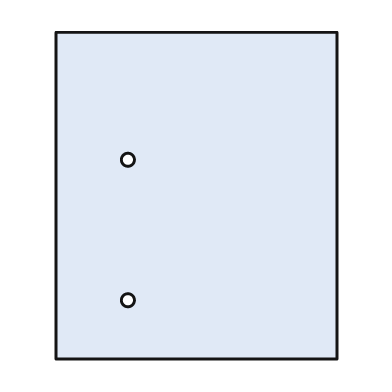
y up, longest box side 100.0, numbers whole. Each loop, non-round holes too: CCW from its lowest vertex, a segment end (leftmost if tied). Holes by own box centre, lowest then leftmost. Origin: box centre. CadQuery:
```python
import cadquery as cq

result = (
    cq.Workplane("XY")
    .moveTo(-43.0, -50.0)
    .lineTo(43.0, -50.0)
    .lineTo(43.0, 50.0)
    .lineTo(-43.0, 50.0)
    .close()
    .moveTo(-21.0, -32.0)
    .circle(2.0)
    .moveTo(-21.0, 11.0)
    .circle(2.0)
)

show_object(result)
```